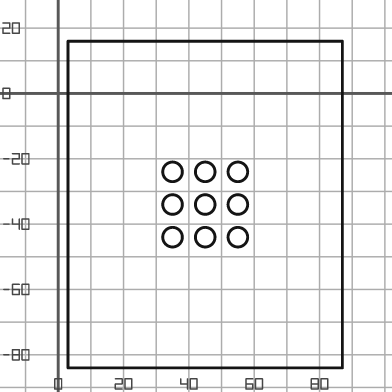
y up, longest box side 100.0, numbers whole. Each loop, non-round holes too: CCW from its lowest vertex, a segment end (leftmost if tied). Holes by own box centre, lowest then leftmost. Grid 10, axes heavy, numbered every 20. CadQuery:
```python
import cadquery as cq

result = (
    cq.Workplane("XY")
    .moveTo(3.0, -84.0)
    .lineTo(87.0, -84.0)
    .lineTo(87.0, 16.0)
    .lineTo(3.0, 16.0)
    .close()
    .moveTo(35.0, -44.0)
    .circle(3.0)
    .moveTo(45.0, -44.0)
    .circle(3.0)
    .moveTo(55.0, -44.0)
    .circle(3.0)
    .moveTo(35.0, -34.0)
    .circle(3.0)
    .moveTo(45.0, -34.0)
    .circle(3.0)
    .moveTo(55.0, -34.0)
    .circle(3.0)
    .moveTo(35.0, -24.0)
    .circle(3.0)
    .moveTo(45.0, -24.0)
    .circle(3.0)
    .moveTo(55.0, -24.0)
    .circle(3.0)
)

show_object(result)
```